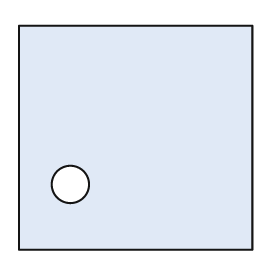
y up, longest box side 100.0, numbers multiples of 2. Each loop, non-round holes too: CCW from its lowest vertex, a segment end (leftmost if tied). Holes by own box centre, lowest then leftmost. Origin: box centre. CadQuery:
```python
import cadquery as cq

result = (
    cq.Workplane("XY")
    .moveTo(-50.0, -48.0)
    .lineTo(50.0, -48.0)
    .lineTo(50.0, 48.0)
    .lineTo(-50.0, 48.0)
    .close()
    .moveTo(-28.0, -20.0)
    .circle(8.0)
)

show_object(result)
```